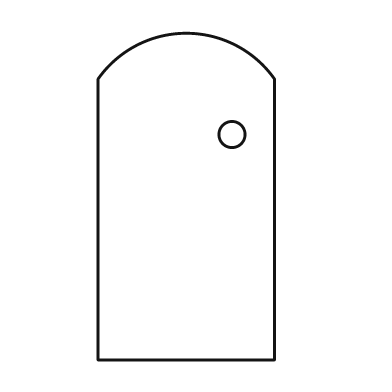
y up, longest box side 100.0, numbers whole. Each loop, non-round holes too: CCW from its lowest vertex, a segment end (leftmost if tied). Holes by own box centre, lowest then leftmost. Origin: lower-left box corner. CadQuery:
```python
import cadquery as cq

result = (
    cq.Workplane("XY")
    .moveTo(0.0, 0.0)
    .lineTo(54.0, 0.0)
    .lineTo(54.0, 86.0)
    .threePointArc((27.0, 100.0), (0.0, 86.0))
    .close()
    .moveTo(41.0, 69.0)
    .circle(4.0)
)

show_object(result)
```